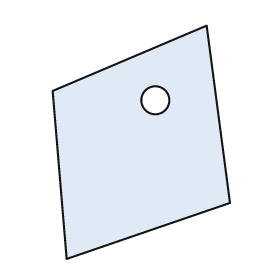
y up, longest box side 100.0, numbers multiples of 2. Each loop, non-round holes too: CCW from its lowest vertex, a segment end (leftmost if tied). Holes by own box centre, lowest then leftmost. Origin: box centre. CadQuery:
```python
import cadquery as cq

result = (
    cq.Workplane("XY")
    .moveTo(-32.0, -50.0)
    .lineTo(38.0, -26.0)
    .lineTo(28.0, 50.0)
    .lineTo(-38.0, 22.0)
    .close()
    .moveTo(6.0, 18.0)
    .circle(6.0)
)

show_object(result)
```